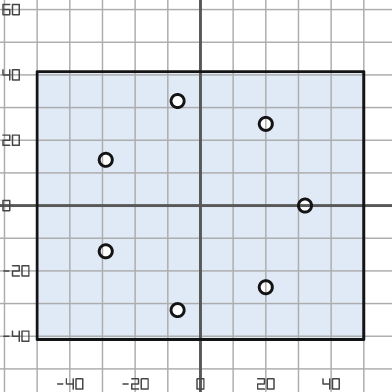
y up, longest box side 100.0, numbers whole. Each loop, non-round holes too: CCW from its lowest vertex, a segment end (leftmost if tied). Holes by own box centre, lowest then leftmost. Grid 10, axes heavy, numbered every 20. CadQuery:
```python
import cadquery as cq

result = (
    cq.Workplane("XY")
    .moveTo(-50.0, -41.0)
    .lineTo(50.0, -41.0)
    .lineTo(50.0, 41.0)
    .lineTo(-50.0, 41.0)
    .close()
    .moveTo(-7.0, -32.0)
    .circle(2.0)
    .moveTo(20.0, -25.0)
    .circle(2.0)
    .moveTo(-29.0, -14.0)
    .circle(2.0)
    .moveTo(32.0, 0.0)
    .circle(2.0)
    .moveTo(-29.0, 14.0)
    .circle(2.0)
    .moveTo(20.0, 25.0)
    .circle(2.0)
    .moveTo(-7.0, 32.0)
    .circle(2.0)
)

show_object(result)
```